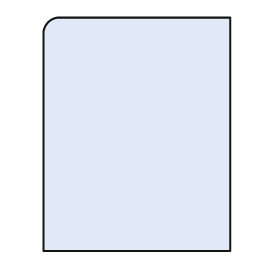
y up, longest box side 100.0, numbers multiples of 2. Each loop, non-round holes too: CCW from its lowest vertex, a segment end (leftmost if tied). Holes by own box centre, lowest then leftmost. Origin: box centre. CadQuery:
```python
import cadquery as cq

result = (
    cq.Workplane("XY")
    .moveTo(-40.0, -50.0)
    .lineTo(40.0, -50.0)
    .lineTo(40.0, 50.0)
    .lineTo(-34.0, 50.0)
    .threePointArc((-38.0, 48.0), (-40.0, 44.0))
    .close()
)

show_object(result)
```